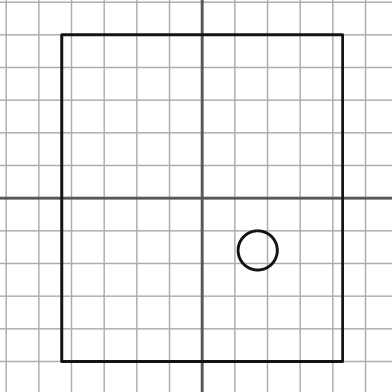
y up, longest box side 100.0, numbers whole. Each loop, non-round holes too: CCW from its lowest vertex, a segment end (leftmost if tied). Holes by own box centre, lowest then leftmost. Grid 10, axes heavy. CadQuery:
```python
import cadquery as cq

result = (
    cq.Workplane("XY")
    .moveTo(-43.0, -50.0)
    .lineTo(43.0, -50.0)
    .lineTo(43.0, 50.0)
    .lineTo(-43.0, 50.0)
    .close()
    .moveTo(17.0, -16.0)
    .circle(6.0)
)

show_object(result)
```